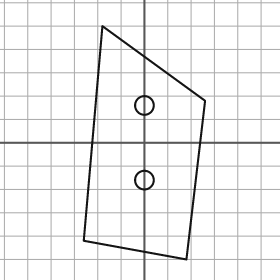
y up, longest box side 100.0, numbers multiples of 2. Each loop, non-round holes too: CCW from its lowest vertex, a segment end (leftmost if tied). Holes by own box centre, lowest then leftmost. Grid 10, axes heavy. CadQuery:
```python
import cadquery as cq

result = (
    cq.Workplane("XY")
    .moveTo(18.0, -50.0)
    .lineTo(26.0, 18.0)
    .lineTo(-18.0, 50.0)
    .lineTo(-26.0, -42.0)
    .close()
    .moveTo(0.0, -16.0)
    .circle(4.0)
    .moveTo(0.0, 16.0)
    .circle(4.0)
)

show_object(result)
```